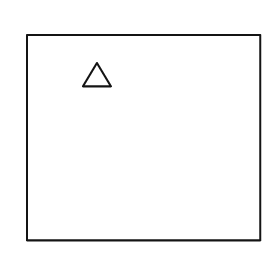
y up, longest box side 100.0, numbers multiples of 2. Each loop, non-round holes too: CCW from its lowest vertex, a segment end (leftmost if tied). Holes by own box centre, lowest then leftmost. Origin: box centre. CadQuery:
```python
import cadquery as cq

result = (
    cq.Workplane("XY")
    .moveTo(-50.0, -44.0)
    .lineTo(50.0, -44.0)
    .lineTo(50.0, 44.0)
    .lineTo(-50.0, 44.0)
    .close()
    .moveTo(-26.0, 22.0)
    .lineTo(-14.0, 22.0)
    .lineTo(-20.0, 32.0)
    .close()
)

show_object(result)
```